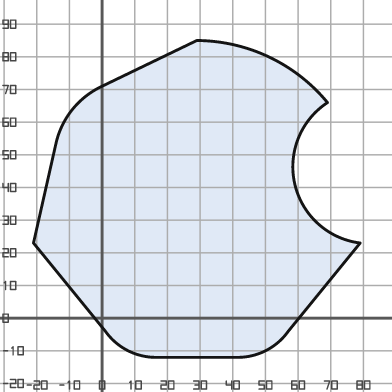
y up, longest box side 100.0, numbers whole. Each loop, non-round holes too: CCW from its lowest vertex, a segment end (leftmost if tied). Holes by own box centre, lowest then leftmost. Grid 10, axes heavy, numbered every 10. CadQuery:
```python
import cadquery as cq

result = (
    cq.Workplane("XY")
    .moveTo(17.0, -12.0)
    .lineTo(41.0, -12.0)
    .threePointArc((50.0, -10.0), (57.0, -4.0))
    .lineTo(79.0, 23.0)
    .threePointArc((59.0, 41.0), (69.0, 66.0))
    .threePointArc((51.0, 80.0), (29.0, 85.0))
    .lineTo(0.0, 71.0)
    .threePointArc((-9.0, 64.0), (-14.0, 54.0))
    .lineTo(-21.0, 23.0)
    .lineTo(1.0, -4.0)
    .threePointArc((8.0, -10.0), (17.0, -12.0))
    .close()
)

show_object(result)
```